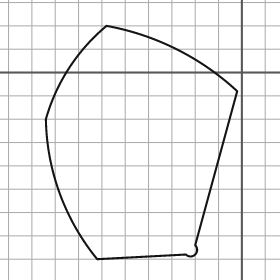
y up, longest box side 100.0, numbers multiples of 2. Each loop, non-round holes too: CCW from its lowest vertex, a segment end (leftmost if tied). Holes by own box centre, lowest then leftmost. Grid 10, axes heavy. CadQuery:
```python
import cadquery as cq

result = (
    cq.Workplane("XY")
    .moveTo(-62.0, -80.0)
    .lineTo(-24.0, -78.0)
    .threePointArc((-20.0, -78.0), (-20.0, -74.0))
    .lineTo(-2.0, -8.0)
    .threePointArc((-28.0, 10.0), (-58.0, 20.0))
    .threePointArc((-74.0, 2.0), (-84.0, -20.0))
    .threePointArc((-78.0, -52.0), (-62.0, -80.0))
    .close()
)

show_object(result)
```